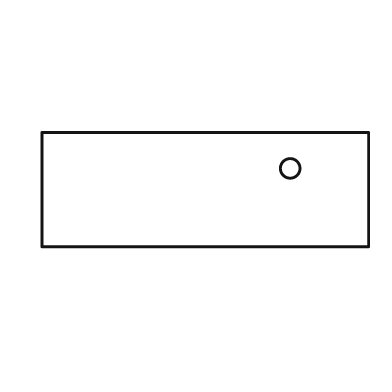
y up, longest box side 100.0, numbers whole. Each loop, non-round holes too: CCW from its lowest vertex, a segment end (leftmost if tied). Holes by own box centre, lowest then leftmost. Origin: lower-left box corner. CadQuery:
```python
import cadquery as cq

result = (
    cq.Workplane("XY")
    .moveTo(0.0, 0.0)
    .lineTo(100.0, 0.0)
    .lineTo(100.0, 35.0)
    .lineTo(0.0, 35.0)
    .close()
    .moveTo(76.0, 24.0)
    .circle(3.0)
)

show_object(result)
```